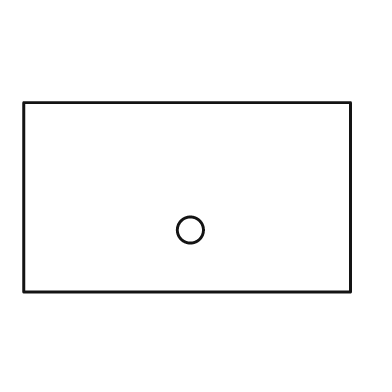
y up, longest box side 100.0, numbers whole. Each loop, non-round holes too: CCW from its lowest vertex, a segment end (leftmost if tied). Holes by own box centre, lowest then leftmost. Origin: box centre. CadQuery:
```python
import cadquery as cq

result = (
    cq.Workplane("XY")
    .moveTo(-50.0, -29.0)
    .lineTo(50.0, -29.0)
    .lineTo(50.0, 29.0)
    .lineTo(-50.0, 29.0)
    .close()
    .moveTo(1.0, -10.0)
    .circle(4.0)
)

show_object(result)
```